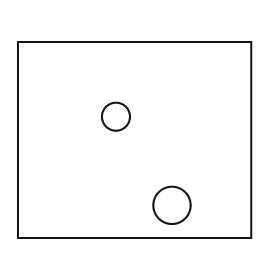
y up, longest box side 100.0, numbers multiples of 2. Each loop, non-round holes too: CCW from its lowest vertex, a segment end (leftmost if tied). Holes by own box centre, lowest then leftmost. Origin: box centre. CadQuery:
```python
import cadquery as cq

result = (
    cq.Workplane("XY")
    .moveTo(-50.0, -42.0)
    .lineTo(50.0, -42.0)
    .lineTo(50.0, 42.0)
    .lineTo(-50.0, 42.0)
    .close()
    .moveTo(16.0, -28.0)
    .circle(8.0)
    .moveTo(-8.0, 10.0)
    .circle(6.0)
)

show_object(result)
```